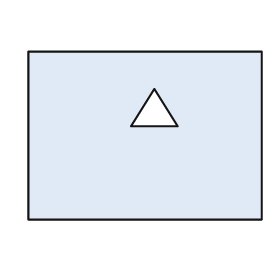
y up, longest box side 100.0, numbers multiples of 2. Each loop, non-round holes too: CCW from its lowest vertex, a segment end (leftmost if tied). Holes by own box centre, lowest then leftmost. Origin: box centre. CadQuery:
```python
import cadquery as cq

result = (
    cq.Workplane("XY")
    .moveTo(-50.0, -36.0)
    .lineTo(50.0, -36.0)
    .lineTo(50.0, 36.0)
    .lineTo(-50.0, 36.0)
    .close()
    .moveTo(-6.0, 4.0)
    .lineTo(14.0, 4.0)
    .lineTo(4.0, 20.0)
    .close()
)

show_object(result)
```